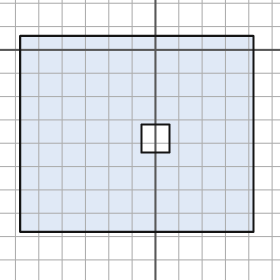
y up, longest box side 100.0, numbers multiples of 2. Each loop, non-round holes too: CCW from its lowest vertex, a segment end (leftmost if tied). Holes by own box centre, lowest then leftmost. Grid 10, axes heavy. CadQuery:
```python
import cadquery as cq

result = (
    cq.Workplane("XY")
    .moveTo(-58.0, -78.0)
    .lineTo(42.0, -78.0)
    .lineTo(42.0, 6.0)
    .lineTo(-58.0, 6.0)
    .close()
    .moveTo(-6.0, -44.0)
    .lineTo(6.0, -44.0)
    .lineTo(6.0, -32.0)
    .lineTo(-6.0, -32.0)
    .close()
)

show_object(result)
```